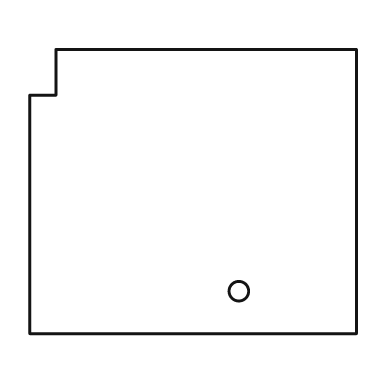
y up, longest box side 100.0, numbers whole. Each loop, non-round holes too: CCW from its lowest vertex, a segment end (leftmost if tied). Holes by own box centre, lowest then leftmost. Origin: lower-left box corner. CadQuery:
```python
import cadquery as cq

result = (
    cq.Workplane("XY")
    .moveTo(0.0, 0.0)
    .lineTo(100.0, 0.0)
    .lineTo(100.0, 87.0)
    .lineTo(8.0, 87.0)
    .lineTo(8.0, 73.0)
    .lineTo(0.0, 73.0)
    .close()
    .moveTo(64.0, 13.0)
    .circle(3.0)
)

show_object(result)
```